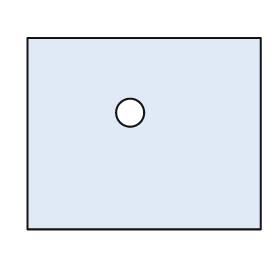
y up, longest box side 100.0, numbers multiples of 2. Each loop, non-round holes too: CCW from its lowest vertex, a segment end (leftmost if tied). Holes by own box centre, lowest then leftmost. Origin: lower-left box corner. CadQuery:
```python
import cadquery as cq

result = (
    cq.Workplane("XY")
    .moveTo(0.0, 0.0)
    .lineTo(100.0, 0.0)
    .lineTo(100.0, 82.0)
    .lineTo(0.0, 82.0)
    .close()
    .moveTo(44.0, 50.0)
    .circle(6.0)
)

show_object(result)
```